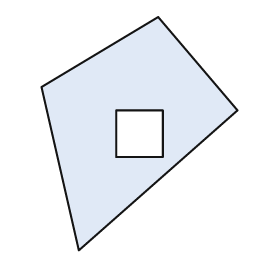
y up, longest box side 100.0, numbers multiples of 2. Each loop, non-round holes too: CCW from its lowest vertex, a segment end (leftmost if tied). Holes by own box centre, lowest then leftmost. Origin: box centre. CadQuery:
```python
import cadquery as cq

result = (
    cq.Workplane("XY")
    .moveTo(-26.0, -50.0)
    .lineTo(42.0, 10.0)
    .lineTo(8.0, 50.0)
    .lineTo(-42.0, 20.0)
    .close()
    .moveTo(-10.0, -10.0)
    .lineTo(10.0, -10.0)
    .lineTo(10.0, 10.0)
    .lineTo(-10.0, 10.0)
    .close()
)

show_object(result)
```